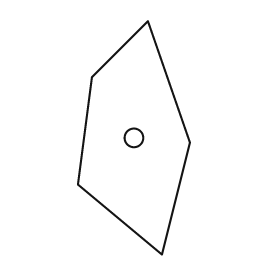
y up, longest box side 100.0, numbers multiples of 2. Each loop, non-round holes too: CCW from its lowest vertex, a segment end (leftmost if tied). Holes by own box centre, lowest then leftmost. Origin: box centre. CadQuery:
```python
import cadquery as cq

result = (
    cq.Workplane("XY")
    .moveTo(12.0, -50.0)
    .lineTo(24.0, -2.0)
    .lineTo(6.0, 50.0)
    .lineTo(-18.0, 26.0)
    .lineTo(-24.0, -20.0)
    .close()
    .moveTo(0.0, 0.0)
    .circle(4.0)
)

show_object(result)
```